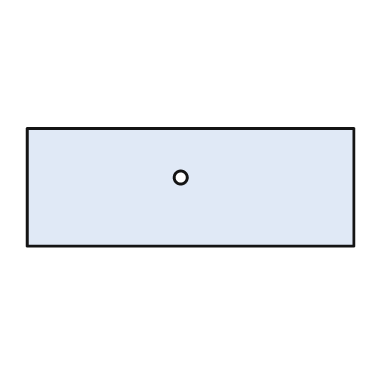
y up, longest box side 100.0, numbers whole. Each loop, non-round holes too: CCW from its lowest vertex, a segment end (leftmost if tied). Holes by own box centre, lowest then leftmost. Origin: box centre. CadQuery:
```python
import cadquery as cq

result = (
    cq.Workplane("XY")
    .moveTo(-50.0, -18.0)
    .lineTo(50.0, -18.0)
    .lineTo(50.0, 18.0)
    .lineTo(-50.0, 18.0)
    .close()
    .moveTo(-3.0, 3.0)
    .circle(2.0)
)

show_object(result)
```